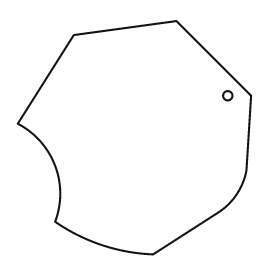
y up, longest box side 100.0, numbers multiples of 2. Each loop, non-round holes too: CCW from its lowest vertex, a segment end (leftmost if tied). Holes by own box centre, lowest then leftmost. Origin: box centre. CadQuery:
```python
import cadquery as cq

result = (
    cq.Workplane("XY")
    .moveTo(8.0, -50.0)
    .lineTo(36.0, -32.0)
    .threePointArc((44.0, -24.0), (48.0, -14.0))
    .lineTo(50.0, 18.0)
    .lineTo(18.0, 50.0)
    .lineTo(-26.0, 44.0)
    .lineTo(-50.0, 6.0)
    .threePointArc((-34.0, -12.0), (-34.0, -36.0))
    .threePointArc((-14.0, -46.0), (8.0, -50.0))
    .close()
    .moveTo(40.0, 18.0)
    .circle(2.0)
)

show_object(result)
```